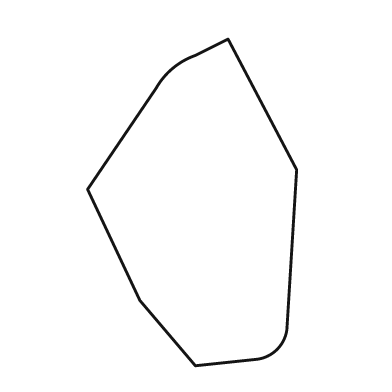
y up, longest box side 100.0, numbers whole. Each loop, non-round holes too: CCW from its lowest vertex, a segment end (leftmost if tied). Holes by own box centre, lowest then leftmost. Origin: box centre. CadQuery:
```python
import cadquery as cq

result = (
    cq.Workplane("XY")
    .moveTo(1.0, -50.0)
    .lineTo(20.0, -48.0)
    .threePointArc((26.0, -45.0), (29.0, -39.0))
    .lineTo(32.0, 10.0)
    .lineTo(11.0, 50.0)
    .lineTo(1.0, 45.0)
    .threePointArc((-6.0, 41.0), (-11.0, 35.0))
    .lineTo(-32.0, 4.0)
    .lineTo(-16.0, -30.0)
    .close()
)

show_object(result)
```